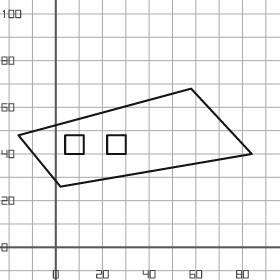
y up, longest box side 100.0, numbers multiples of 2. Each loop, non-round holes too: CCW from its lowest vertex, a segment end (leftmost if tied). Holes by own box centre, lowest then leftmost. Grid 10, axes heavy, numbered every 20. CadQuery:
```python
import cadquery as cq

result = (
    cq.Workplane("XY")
    .moveTo(2.0, 26.0)
    .lineTo(84.0, 40.0)
    .lineTo(58.0, 68.0)
    .lineTo(-16.0, 48.0)
    .close()
    .moveTo(4.0, 40.0)
    .lineTo(12.0, 40.0)
    .lineTo(12.0, 48.0)
    .lineTo(4.0, 48.0)
    .close()
    .moveTo(22.0, 40.0)
    .lineTo(30.0, 40.0)
    .lineTo(30.0, 48.0)
    .lineTo(22.0, 48.0)
    .close()
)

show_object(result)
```